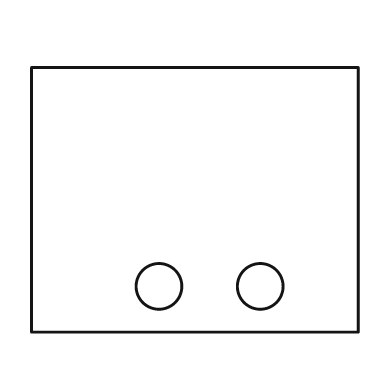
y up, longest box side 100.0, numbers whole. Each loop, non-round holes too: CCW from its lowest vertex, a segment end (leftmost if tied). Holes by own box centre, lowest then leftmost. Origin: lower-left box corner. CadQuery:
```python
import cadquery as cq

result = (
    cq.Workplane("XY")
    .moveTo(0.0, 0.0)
    .lineTo(100.0, 0.0)
    .lineTo(100.0, 81.0)
    .lineTo(0.0, 81.0)
    .close()
    .moveTo(39.0, 14.0)
    .circle(7.0)
    .moveTo(70.0, 14.0)
    .circle(7.0)
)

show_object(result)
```